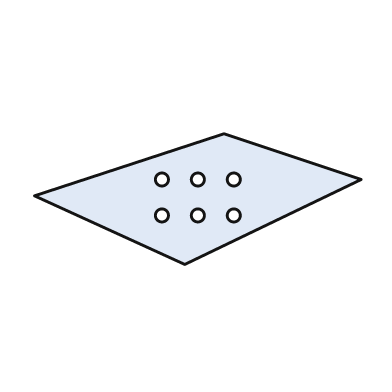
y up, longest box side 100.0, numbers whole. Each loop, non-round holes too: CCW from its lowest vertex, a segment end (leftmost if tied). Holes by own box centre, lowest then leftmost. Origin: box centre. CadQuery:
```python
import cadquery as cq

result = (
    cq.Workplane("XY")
    .moveTo(-4.0, -20.0)
    .lineTo(50.0, 6.0)
    .lineTo(8.0, 20.0)
    .lineTo(-50.0, 1.0)
    .close()
    .moveTo(-11.0, -5.0)
    .circle(2.0)
    .moveTo(0.0, -5.0)
    .circle(2.0)
    .moveTo(11.0, -5.0)
    .circle(2.0)
    .moveTo(-11.0, 6.0)
    .circle(2.0)
    .moveTo(0.0, 6.0)
    .circle(2.0)
    .moveTo(11.0, 6.0)
    .circle(2.0)
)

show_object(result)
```